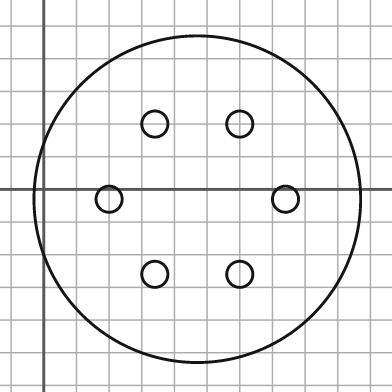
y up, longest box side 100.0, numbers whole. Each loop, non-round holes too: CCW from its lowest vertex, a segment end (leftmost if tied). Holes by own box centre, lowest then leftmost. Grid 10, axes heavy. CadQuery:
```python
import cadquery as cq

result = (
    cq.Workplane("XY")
    .moveTo(47.0, -3.0)
    .circle(50.0)
    .moveTo(34.0, -26.0)
    .circle(4.0)
    .moveTo(60.0, -26.0)
    .circle(4.0)
    .moveTo(20.0, -3.0)
    .circle(4.0)
    .moveTo(74.0, -3.0)
    .circle(4.0)
    .moveTo(34.0, 20.0)
    .circle(4.0)
    .moveTo(60.0, 20.0)
    .circle(4.0)
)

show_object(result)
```